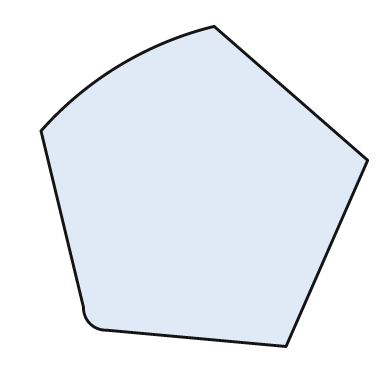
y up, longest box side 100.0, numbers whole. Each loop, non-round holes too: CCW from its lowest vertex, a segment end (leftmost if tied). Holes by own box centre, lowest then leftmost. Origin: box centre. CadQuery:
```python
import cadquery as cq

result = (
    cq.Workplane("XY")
    .moveTo(25.0, -49.0)
    .lineTo(50.0, 8.0)
    .lineTo(3.0, 49.0)
    .threePointArc((-26.0, 37.0), (-50.0, 17.0))
    .lineTo(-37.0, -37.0)
    .threePointArc((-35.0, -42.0), (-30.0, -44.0))
    .close()
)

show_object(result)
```